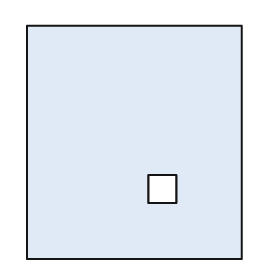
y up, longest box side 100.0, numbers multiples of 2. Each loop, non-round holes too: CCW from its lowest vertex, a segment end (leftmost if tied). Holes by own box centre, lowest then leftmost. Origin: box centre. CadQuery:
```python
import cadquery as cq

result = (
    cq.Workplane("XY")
    .moveTo(-46.0, -50.0)
    .lineTo(46.0, -50.0)
    .lineTo(46.0, 50.0)
    .lineTo(-46.0, 50.0)
    .close()
    .moveTo(6.0, -26.0)
    .lineTo(18.0, -26.0)
    .lineTo(18.0, -14.0)
    .lineTo(6.0, -14.0)
    .close()
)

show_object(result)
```